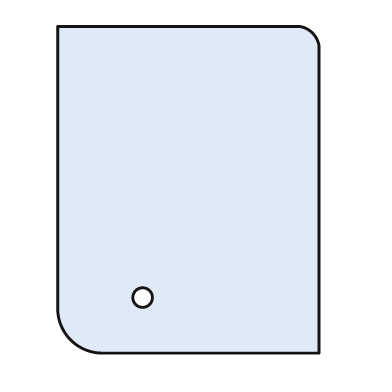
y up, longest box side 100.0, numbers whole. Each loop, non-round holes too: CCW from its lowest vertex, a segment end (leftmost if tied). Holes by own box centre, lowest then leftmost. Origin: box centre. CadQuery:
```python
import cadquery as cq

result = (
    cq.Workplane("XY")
    .moveTo(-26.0, -50.0)
    .lineTo(40.0, -50.0)
    .lineTo(40.0, 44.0)
    .threePointArc((38.0, 48.0), (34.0, 50.0))
    .lineTo(-40.0, 50.0)
    .lineTo(-40.0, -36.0)
    .threePointArc((-36.0, -46.0), (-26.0, -50.0))
    .close()
    .moveTo(-14.0, -33.0)
    .circle(3.0)
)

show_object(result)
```